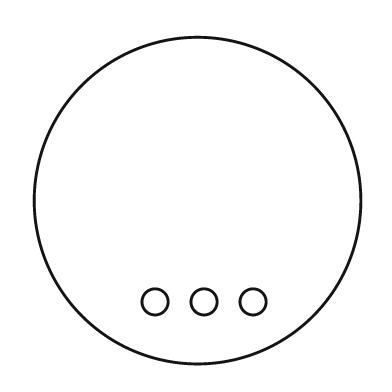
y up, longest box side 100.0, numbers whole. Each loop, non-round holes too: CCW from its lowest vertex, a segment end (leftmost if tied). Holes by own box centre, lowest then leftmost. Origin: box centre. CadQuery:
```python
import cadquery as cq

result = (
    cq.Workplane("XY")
    .moveTo(0.0, 0.0)
    .circle(50.0)
    .moveTo(-13.0, -31.0)
    .circle(4.0)
    .moveTo(2.0, -31.0)
    .circle(4.0)
    .moveTo(17.0, -31.0)
    .circle(4.0)
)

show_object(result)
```